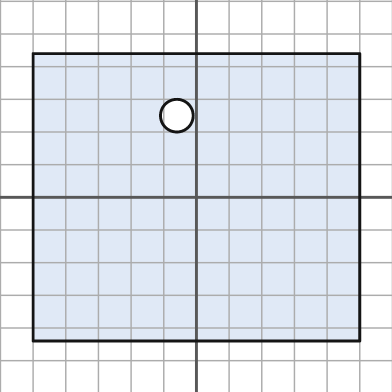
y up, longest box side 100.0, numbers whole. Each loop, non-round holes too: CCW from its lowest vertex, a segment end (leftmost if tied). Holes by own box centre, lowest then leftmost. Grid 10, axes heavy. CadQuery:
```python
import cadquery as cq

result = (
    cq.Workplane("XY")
    .moveTo(-50.0, -44.0)
    .lineTo(50.0, -44.0)
    .lineTo(50.0, 44.0)
    .lineTo(-50.0, 44.0)
    .close()
    .moveTo(-6.0, 25.0)
    .circle(5.0)
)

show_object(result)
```